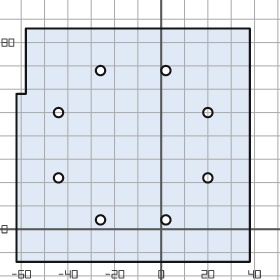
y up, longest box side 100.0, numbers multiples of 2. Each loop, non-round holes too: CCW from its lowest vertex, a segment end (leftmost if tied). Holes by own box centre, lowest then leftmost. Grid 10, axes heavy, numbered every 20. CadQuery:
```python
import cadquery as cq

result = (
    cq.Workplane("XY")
    .moveTo(-62.0, -14.0)
    .lineTo(38.0, -14.0)
    .lineTo(38.0, 86.0)
    .lineTo(-58.0, 86.0)
    .lineTo(-58.0, 58.0)
    .lineTo(-62.0, 58.0)
    .close()
    .moveTo(-26.0, 4.0)
    .circle(2.0)
    .moveTo(2.0, 4.0)
    .circle(2.0)
    .moveTo(-44.0, 22.0)
    .circle(2.0)
    .moveTo(20.0, 22.0)
    .circle(2.0)
    .moveTo(-44.0, 50.0)
    .circle(2.0)
    .moveTo(20.0, 50.0)
    .circle(2.0)
    .moveTo(-26.0, 68.0)
    .circle(2.0)
    .moveTo(2.0, 68.0)
    .circle(2.0)
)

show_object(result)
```